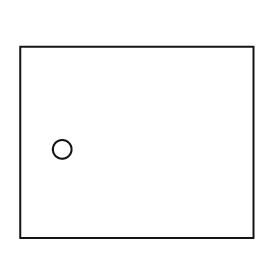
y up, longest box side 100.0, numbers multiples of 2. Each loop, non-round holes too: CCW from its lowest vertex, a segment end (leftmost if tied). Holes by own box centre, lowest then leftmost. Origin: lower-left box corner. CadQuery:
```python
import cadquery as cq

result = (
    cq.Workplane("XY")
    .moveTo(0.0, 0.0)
    .lineTo(100.0, 0.0)
    .lineTo(100.0, 82.0)
    .lineTo(0.0, 82.0)
    .close()
    .moveTo(18.0, 38.0)
    .circle(4.0)
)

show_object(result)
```